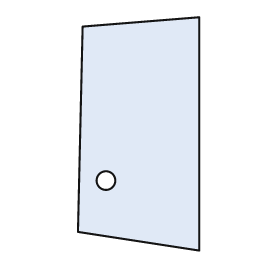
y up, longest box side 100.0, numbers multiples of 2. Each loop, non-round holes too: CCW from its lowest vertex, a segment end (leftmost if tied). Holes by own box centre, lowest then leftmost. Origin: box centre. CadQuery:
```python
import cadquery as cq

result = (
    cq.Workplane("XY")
    .moveTo(26.0, -50.0)
    .lineTo(26.0, 50.0)
    .lineTo(-24.0, 46.0)
    .lineTo(-26.0, -42.0)
    .close()
    .moveTo(-14.0, -20.0)
    .circle(4.0)
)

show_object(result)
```